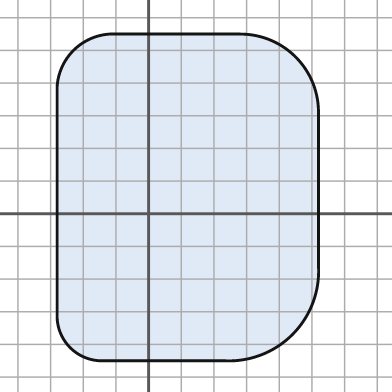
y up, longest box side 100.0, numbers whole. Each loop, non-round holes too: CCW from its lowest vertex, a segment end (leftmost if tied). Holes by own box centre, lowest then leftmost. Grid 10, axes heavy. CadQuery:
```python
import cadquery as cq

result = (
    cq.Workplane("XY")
    .moveTo(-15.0, -45.0)
    .lineTo(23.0, -45.0)
    .threePointArc((44.0, -37.0), (52.0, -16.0))
    .lineTo(52.0, 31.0)
    .threePointArc((45.0, 48.0), (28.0, 55.0))
    .lineTo(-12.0, 55.0)
    .threePointArc((-23.0, 50.0), (-28.0, 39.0))
    .lineTo(-28.0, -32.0)
    .threePointArc((-24.0, -41.0), (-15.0, -45.0))
    .close()
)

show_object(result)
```